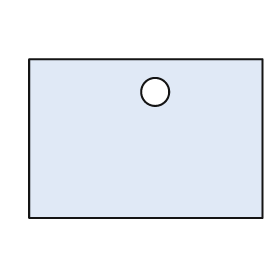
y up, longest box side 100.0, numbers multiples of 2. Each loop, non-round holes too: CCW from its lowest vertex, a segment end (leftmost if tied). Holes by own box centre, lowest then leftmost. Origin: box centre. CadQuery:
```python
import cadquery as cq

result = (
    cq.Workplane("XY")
    .moveTo(-50.0, -34.0)
    .lineTo(50.0, -34.0)
    .lineTo(50.0, 34.0)
    .lineTo(-50.0, 34.0)
    .close()
    .moveTo(4.0, 20.0)
    .circle(6.0)
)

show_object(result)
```